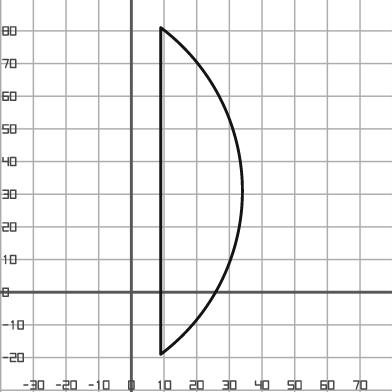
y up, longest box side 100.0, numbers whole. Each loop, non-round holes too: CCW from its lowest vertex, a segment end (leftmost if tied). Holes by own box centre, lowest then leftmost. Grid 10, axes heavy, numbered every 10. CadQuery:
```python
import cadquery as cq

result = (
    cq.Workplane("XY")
    .moveTo(9.0, -19.0)
    .threePointArc((34.0, 31.0), (9.0, 81.0))
    .close()
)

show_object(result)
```